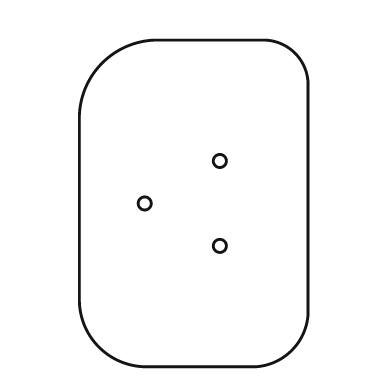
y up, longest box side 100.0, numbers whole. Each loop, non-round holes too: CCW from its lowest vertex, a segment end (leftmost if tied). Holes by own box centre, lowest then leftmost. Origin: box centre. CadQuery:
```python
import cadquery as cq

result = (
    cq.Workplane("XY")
    .moveTo(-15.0, -50.0)
    .lineTo(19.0, -50.0)
    .threePointArc((30.0, -45.0), (35.0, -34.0))
    .lineTo(35.0, 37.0)
    .threePointArc((31.0, 46.0), (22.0, 50.0))
    .lineTo(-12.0, 50.0)
    .threePointArc((-28.0, 43.0), (-35.0, 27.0))
    .lineTo(-35.0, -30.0)
    .threePointArc((-29.0, -44.0), (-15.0, -50.0))
    .close()
    .moveTo(8.0, -13.0)
    .circle(2.0)
    .moveTo(-15.0, 0.0)
    .circle(2.0)
    .moveTo(8.0, 13.0)
    .circle(2.0)
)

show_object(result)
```